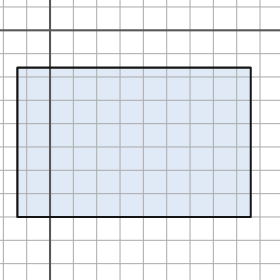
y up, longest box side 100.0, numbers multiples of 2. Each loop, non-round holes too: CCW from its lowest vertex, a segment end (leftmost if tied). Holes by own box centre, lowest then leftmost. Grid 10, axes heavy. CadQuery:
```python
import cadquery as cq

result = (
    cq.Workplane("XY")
    .moveTo(-14.0, -80.0)
    .lineTo(86.0, -80.0)
    .lineTo(86.0, -16.0)
    .lineTo(-14.0, -16.0)
    .close()
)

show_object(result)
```